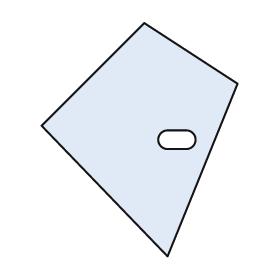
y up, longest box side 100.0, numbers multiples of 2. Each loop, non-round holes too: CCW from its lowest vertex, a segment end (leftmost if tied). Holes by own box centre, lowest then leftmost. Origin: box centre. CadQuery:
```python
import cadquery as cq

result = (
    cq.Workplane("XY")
    .moveTo(12.0, -50.0)
    .lineTo(42.0, 24.0)
    .lineTo(2.0, 50.0)
    .lineTo(-42.0, 6.0)
    .close()
    .moveTo(12.0, -4.0)
    .lineTo(20.0, -4.0)
    .threePointArc((24.0, 0.0), (20.0, 4.0))
    .lineTo(12.0, 4.0)
    .threePointArc((8.0, 0.0), (12.0, -4.0))
    .close()
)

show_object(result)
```